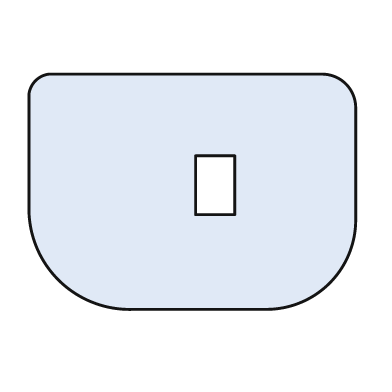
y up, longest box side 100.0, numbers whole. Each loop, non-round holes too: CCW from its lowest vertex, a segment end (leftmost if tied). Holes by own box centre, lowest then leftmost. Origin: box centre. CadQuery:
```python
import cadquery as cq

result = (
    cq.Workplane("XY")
    .moveTo(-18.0, -36.0)
    .lineTo(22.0, -36.0)
    .threePointArc((42.0, -28.0), (50.0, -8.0))
    .lineTo(50.0, 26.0)
    .threePointArc((47.0, 33.0), (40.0, 36.0))
    .lineTo(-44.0, 36.0)
    .threePointArc((-48.0, 34.0), (-50.0, 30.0))
    .lineTo(-50.0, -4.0)
    .threePointArc((-41.0, -27.0), (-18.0, -36.0))
    .close()
    .moveTo(1.0, -7.0)
    .lineTo(13.0, -7.0)
    .lineTo(13.0, 11.0)
    .lineTo(1.0, 11.0)
    .close()
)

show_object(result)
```